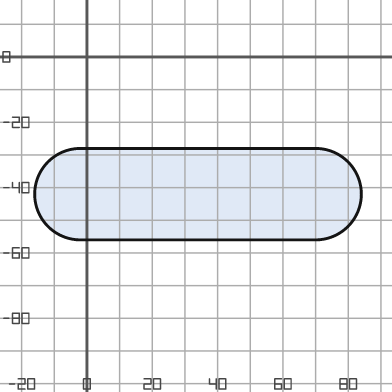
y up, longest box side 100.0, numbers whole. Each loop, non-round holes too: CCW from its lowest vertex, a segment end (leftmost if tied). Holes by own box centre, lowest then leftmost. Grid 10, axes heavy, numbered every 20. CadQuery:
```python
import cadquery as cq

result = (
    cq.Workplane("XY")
    .moveTo(-2.0, -56.0)
    .lineTo(70.0, -56.0)
    .threePointArc((84.0, -42.0), (70.0, -28.0))
    .lineTo(-2.0, -28.0)
    .threePointArc((-16.0, -42.0), (-2.0, -56.0))
    .close()
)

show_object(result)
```